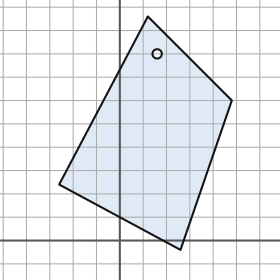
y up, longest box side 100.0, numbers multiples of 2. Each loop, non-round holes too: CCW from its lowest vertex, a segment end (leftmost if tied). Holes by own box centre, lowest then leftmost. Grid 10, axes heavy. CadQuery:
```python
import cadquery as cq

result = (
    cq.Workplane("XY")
    .moveTo(26.0, -4.0)
    .lineTo(48.0, 60.0)
    .lineTo(12.0, 96.0)
    .lineTo(-26.0, 24.0)
    .close()
    .moveTo(16.0, 80.0)
    .circle(2.0)
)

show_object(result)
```